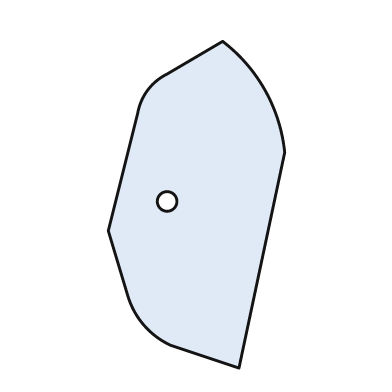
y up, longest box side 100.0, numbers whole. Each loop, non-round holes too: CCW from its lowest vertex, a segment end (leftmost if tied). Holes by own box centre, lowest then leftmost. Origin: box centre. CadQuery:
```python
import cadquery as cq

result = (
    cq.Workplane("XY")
    .moveTo(13.0, -50.0)
    .lineTo(27.0, 16.0)
    .threePointArc((21.0, 35.0), (8.0, 50.0))
    .lineTo(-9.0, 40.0)
    .threePointArc((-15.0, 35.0), (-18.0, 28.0))
    .lineTo(-27.0, -8.0)
    .lineTo(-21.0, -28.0)
    .threePointArc((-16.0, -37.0), (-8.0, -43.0))
    .close()
    .moveTo(-9.0, 1.0)
    .circle(3.0)
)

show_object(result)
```